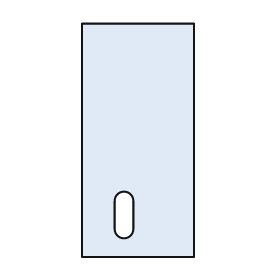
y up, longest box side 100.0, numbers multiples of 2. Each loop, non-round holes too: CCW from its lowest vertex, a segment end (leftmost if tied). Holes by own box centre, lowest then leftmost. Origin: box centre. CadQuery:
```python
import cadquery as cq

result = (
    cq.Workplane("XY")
    .moveTo(-24.0, -50.0)
    .lineTo(24.0, -50.0)
    .lineTo(24.0, 50.0)
    .lineTo(-24.0, 50.0)
    .close()
    .moveTo(-10.0, -38.0)
    .threePointArc((-6.0, -42.0), (-2.0, -38.0))
    .lineTo(-2.0, -26.0)
    .threePointArc((-6.0, -22.0), (-10.0, -26.0))
    .close()
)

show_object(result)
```